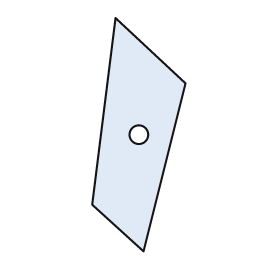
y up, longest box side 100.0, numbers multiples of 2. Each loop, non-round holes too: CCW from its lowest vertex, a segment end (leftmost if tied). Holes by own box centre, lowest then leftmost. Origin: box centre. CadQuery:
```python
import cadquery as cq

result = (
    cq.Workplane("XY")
    .moveTo(2.0, -50.0)
    .lineTo(20.0, 22.0)
    .lineTo(-10.0, 50.0)
    .lineTo(-20.0, -30.0)
    .close()
    .moveTo(0.0, 0.0)
    .circle(4.0)
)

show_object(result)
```